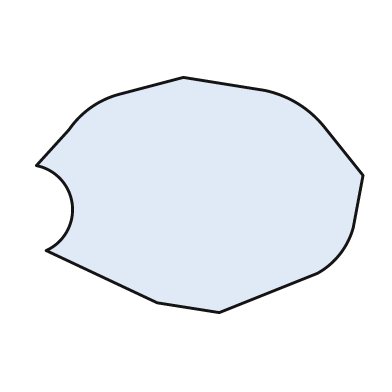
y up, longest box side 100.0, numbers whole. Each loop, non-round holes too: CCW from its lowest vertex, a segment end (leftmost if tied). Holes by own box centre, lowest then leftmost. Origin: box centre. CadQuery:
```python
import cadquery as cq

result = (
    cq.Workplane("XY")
    .moveTo(6.0, -36.0)
    .lineTo(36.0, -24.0)
    .threePointArc((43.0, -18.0), (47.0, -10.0))
    .lineTo(50.0, 6.0)
    .lineTo(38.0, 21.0)
    .threePointArc((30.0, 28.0), (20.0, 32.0))
    .lineTo(-5.0, 36.0)
    .lineTo(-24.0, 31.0)
    .threePointArc((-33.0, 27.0), (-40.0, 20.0))
    .lineTo(-50.0, 9.0)
    .threePointArc((-39.0, -3.0), (-47.0, -17.0))
    .lineTo(-13.0, -33.0)
    .close()
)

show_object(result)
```